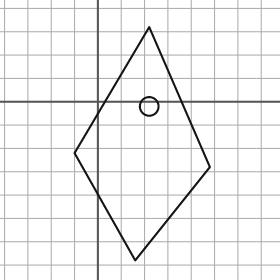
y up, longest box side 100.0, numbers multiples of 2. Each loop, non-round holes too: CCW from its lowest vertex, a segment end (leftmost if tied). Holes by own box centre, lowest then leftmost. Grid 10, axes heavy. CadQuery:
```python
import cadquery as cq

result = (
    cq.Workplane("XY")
    .moveTo(16.0, -68.0)
    .lineTo(48.0, -28.0)
    .lineTo(22.0, 32.0)
    .lineTo(-10.0, -22.0)
    .close()
    .moveTo(22.0, -2.0)
    .circle(4.0)
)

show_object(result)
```